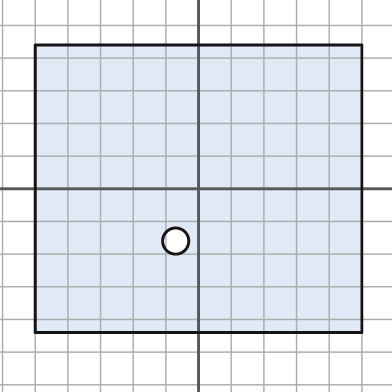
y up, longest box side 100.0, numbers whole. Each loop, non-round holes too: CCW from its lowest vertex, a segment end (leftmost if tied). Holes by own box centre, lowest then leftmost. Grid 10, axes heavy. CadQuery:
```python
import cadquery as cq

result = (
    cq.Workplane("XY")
    .moveTo(-50.0, -44.0)
    .lineTo(50.0, -44.0)
    .lineTo(50.0, 44.0)
    .lineTo(-50.0, 44.0)
    .close()
    .moveTo(-7.0, -16.0)
    .circle(4.0)
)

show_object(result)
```